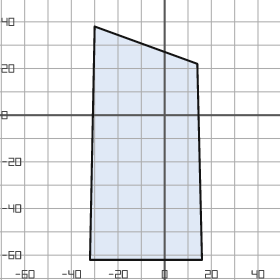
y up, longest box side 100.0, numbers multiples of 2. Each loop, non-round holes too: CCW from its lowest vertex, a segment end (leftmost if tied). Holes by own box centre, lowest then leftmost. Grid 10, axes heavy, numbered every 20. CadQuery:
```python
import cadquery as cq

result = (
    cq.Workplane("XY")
    .moveTo(-32.0, -62.0)
    .lineTo(16.0, -62.0)
    .lineTo(14.0, 22.0)
    .lineTo(-30.0, 38.0)
    .close()
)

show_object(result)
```